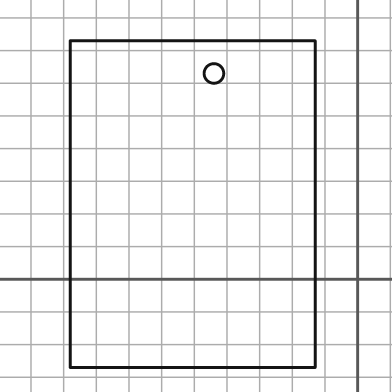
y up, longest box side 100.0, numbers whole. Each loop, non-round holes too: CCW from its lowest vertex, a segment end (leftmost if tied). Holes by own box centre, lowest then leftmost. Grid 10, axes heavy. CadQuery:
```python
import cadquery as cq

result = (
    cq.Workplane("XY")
    .moveTo(-88.0, -27.0)
    .lineTo(-13.0, -27.0)
    .lineTo(-13.0, 73.0)
    .lineTo(-88.0, 73.0)
    .close()
    .moveTo(-44.0, 63.0)
    .circle(3.0)
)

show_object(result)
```